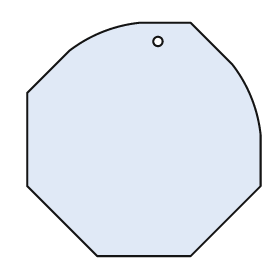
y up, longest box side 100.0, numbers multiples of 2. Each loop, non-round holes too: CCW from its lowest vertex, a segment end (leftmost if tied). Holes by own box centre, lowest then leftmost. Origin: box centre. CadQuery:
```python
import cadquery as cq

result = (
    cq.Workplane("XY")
    .moveTo(-20.0, -50.0)
    .lineTo(20.0, -50.0)
    .lineTo(50.0, -20.0)
    .lineTo(50.0, 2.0)
    .threePointArc((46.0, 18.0), (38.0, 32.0))
    .lineTo(20.0, 50.0)
    .lineTo(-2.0, 50.0)
    .threePointArc((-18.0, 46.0), (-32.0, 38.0))
    .lineTo(-50.0, 20.0)
    .lineTo(-50.0, -20.0)
    .close()
    .moveTo(6.0, 42.0)
    .circle(2.0)
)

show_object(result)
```